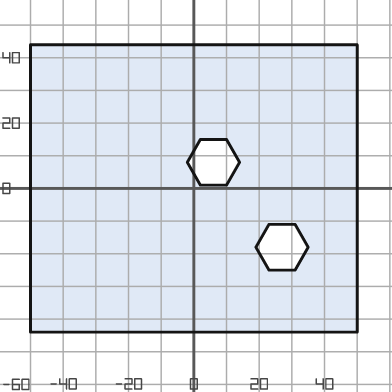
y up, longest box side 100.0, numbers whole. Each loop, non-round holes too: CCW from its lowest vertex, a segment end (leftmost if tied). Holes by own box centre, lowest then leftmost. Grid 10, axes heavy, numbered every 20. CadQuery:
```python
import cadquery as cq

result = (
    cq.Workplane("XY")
    .moveTo(-50.0, -44.0)
    .lineTo(50.0, -44.0)
    .lineTo(50.0, 44.0)
    .lineTo(-50.0, 44.0)
    .close()
    .moveTo(23.0, -25.0)
    .lineTo(31.0, -25.0)
    .lineTo(35.0, -18.0)
    .lineTo(31.0, -11.0)
    .lineTo(23.0, -11.0)
    .lineTo(19.0, -18.0)
    .close()
    .moveTo(2.0, 1.0)
    .lineTo(10.0, 1.0)
    .lineTo(14.0, 8.0)
    .lineTo(10.0, 15.0)
    .lineTo(2.0, 15.0)
    .lineTo(-2.0, 8.0)
    .close()
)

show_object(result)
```